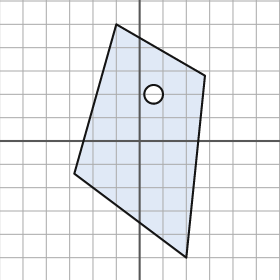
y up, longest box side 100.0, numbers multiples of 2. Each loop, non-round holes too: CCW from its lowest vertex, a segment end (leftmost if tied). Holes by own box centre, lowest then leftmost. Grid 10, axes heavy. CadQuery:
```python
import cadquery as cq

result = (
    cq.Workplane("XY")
    .moveTo(20.0, -50.0)
    .lineTo(28.0, 28.0)
    .lineTo(-10.0, 50.0)
    .lineTo(-28.0, -14.0)
    .close()
    .moveTo(6.0, 20.0)
    .circle(4.0)
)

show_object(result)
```